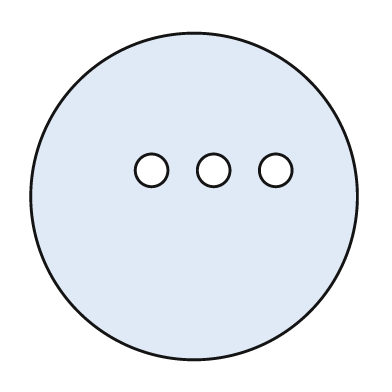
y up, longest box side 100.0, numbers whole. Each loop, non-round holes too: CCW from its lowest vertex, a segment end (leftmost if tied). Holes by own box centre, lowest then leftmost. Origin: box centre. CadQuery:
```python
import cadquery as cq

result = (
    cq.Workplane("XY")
    .moveTo(0.0, 0.0)
    .circle(50.0)
    .moveTo(-13.0, 8.0)
    .circle(5.0)
    .moveTo(6.0, 8.0)
    .circle(5.0)
    .moveTo(25.0, 8.0)
    .circle(5.0)
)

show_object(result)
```